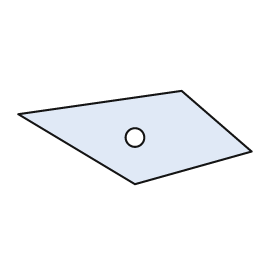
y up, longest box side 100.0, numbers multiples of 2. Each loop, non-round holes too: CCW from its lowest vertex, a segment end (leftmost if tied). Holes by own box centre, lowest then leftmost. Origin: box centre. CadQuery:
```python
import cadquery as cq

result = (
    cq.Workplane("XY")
    .moveTo(0.0, -20.0)
    .lineTo(50.0, -6.0)
    .lineTo(20.0, 20.0)
    .lineTo(-50.0, 10.0)
    .close()
    .moveTo(0.0, 0.0)
    .circle(4.0)
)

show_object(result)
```